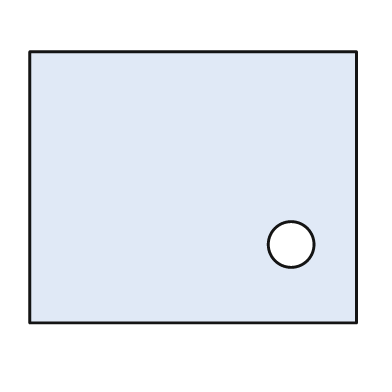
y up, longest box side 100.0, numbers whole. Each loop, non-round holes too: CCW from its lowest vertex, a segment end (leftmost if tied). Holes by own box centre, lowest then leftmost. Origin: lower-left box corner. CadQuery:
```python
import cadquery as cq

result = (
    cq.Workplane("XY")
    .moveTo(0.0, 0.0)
    .lineTo(100.0, 0.0)
    .lineTo(100.0, 83.0)
    .lineTo(0.0, 83.0)
    .close()
    .moveTo(80.0, 24.0)
    .circle(7.0)
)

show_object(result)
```